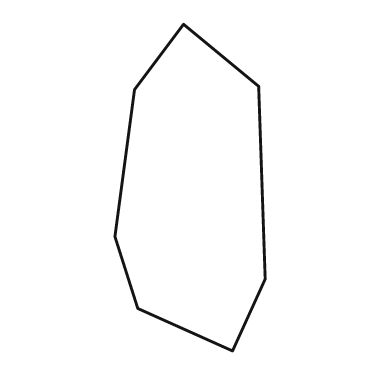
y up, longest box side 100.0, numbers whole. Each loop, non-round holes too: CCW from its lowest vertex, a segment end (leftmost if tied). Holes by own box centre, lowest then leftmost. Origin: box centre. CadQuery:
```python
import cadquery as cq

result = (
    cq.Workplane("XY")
    .moveTo(13.0, -50.0)
    .lineTo(23.0, -28.0)
    .lineTo(21.0, 31.0)
    .lineTo(-2.0, 50.0)
    .lineTo(-17.0, 30.0)
    .lineTo(-23.0, -15.0)
    .lineTo(-16.0, -37.0)
    .close()
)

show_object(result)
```